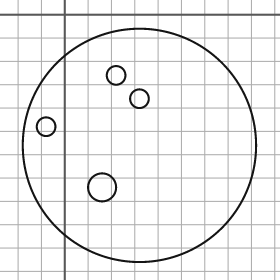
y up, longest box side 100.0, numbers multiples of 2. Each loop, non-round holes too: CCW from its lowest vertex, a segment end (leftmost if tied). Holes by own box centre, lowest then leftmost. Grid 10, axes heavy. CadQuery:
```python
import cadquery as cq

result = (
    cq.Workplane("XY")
    .moveTo(32.0, -56.0)
    .circle(50.0)
    .moveTo(16.0, -74.0)
    .circle(6.0)
    .moveTo(-8.0, -48.0)
    .circle(4.0)
    .moveTo(32.0, -36.0)
    .circle(4.0)
    .moveTo(22.0, -26.0)
    .circle(4.0)
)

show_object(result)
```